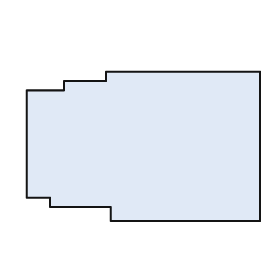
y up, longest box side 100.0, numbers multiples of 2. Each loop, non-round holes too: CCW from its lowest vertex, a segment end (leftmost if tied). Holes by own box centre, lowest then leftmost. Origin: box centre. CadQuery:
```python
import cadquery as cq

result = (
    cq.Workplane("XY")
    .moveTo(-14.0, -32.0)
    .lineTo(50.0, -32.0)
    .lineTo(50.0, 32.0)
    .lineTo(-16.0, 32.0)
    .lineTo(-16.0, 28.0)
    .lineTo(-34.0, 28.0)
    .lineTo(-34.0, 24.0)
    .lineTo(-50.0, 24.0)
    .lineTo(-50.0, -22.0)
    .lineTo(-40.0, -22.0)
    .lineTo(-40.0, -26.0)
    .lineTo(-14.0, -26.0)
    .close()
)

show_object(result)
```